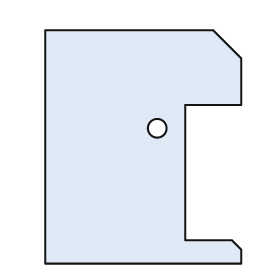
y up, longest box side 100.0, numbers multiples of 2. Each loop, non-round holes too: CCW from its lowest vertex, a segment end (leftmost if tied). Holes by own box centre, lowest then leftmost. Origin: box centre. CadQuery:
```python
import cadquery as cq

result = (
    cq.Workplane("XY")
    .moveTo(-42.0, -50.0)
    .lineTo(42.0, -50.0)
    .lineTo(42.0, -44.0)
    .lineTo(38.0, -40.0)
    .lineTo(18.0, -40.0)
    .lineTo(18.0, 18.0)
    .lineTo(42.0, 18.0)
    .lineTo(42.0, 38.0)
    .lineTo(30.0, 50.0)
    .lineTo(-42.0, 50.0)
    .close()
    .moveTo(6.0, 8.0)
    .circle(4.0)
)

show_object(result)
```